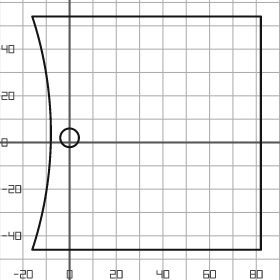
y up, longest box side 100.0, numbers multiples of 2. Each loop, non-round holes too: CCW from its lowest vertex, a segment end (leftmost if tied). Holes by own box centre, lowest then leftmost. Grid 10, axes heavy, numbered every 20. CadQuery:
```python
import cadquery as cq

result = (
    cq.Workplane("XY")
    .moveTo(-16.0, -46.0)
    .lineTo(82.0, -46.0)
    .lineTo(82.0, 54.0)
    .lineTo(-16.0, 54.0)
    .threePointArc((-8.0, 4.0), (-16.0, -46.0))
    .close()
    .moveTo(0.0, 2.0)
    .circle(4.0)
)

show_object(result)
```